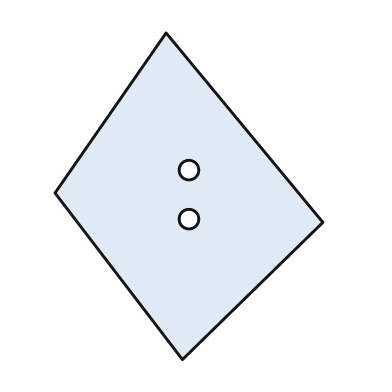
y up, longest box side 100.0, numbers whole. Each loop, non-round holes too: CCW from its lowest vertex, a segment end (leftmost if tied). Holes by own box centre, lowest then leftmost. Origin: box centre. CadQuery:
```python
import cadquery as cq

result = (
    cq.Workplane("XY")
    .moveTo(-2.0, -50.0)
    .lineTo(41.0, -8.0)
    .lineTo(-7.0, 50.0)
    .lineTo(-41.0, 1.0)
    .close()
    .moveTo(0.0, -7.0)
    .circle(3.0)
    .moveTo(0.0, 8.0)
    .circle(3.0)
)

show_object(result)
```